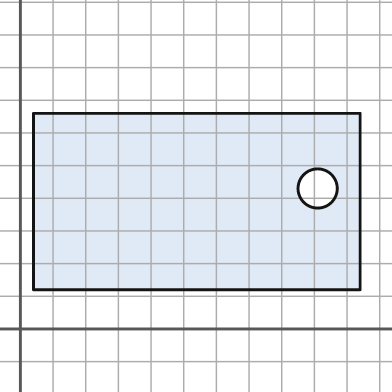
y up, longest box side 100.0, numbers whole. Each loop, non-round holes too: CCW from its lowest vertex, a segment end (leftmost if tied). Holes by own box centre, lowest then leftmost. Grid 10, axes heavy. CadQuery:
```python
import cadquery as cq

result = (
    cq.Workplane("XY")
    .moveTo(4.0, 12.0)
    .lineTo(104.0, 12.0)
    .lineTo(104.0, 66.0)
    .lineTo(4.0, 66.0)
    .close()
    .moveTo(91.0, 43.0)
    .circle(6.0)
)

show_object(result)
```